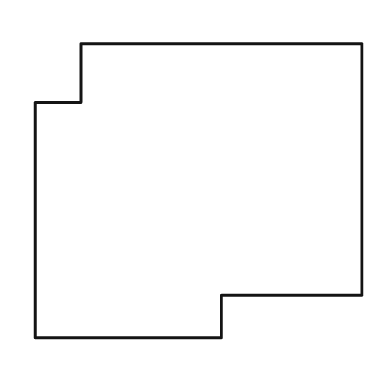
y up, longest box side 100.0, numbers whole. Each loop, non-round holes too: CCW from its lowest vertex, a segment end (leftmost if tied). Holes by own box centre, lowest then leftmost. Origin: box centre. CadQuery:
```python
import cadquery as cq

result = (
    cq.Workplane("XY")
    .moveTo(-50.0, -45.0)
    .lineTo(7.0, -45.0)
    .lineTo(7.0, -32.0)
    .lineTo(50.0, -32.0)
    .lineTo(50.0, 45.0)
    .lineTo(-36.0, 45.0)
    .lineTo(-36.0, 27.0)
    .lineTo(-50.0, 27.0)
    .close()
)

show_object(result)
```